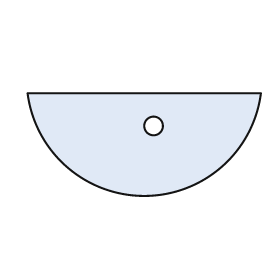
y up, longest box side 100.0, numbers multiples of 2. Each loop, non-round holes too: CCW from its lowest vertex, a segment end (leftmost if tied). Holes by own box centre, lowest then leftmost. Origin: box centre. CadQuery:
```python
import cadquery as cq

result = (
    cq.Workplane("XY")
    .moveTo(-50.0, 22.0)
    .threePointArc((0.0, -22.0), (50.0, 22.0))
    .close()
    .moveTo(4.0, 8.0)
    .circle(4.0)
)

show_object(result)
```